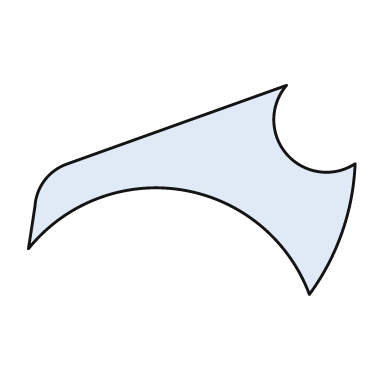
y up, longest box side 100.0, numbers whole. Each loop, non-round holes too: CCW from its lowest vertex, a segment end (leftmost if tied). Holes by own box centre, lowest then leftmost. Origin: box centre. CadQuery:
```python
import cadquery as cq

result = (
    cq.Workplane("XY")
    .moveTo(36.0, -32.0)
    .threePointArc((46.0, -13.0), (50.0, 8.0))
    .threePointArc((29.0, 11.0), (29.0, 32.0))
    .lineTo(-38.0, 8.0)
    .threePointArc((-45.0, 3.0), (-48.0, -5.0))
    .lineTo(-50.0, -18.0)
    .threePointArc((-3.0, 0.0), (36.0, -32.0))
    .close()
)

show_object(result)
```